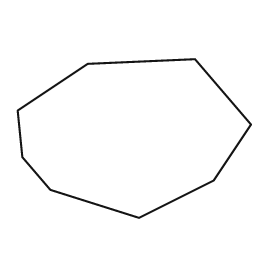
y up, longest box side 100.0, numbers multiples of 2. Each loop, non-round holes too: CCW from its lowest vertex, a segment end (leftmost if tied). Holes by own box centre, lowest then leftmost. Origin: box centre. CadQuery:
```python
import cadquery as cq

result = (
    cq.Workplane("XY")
    .moveTo(2.0, -34.0)
    .lineTo(34.0, -18.0)
    .lineTo(50.0, 6.0)
    .lineTo(26.0, 34.0)
    .lineTo(-20.0, 32.0)
    .lineTo(-50.0, 12.0)
    .lineTo(-48.0, -8.0)
    .lineTo(-36.0, -22.0)
    .close()
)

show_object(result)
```